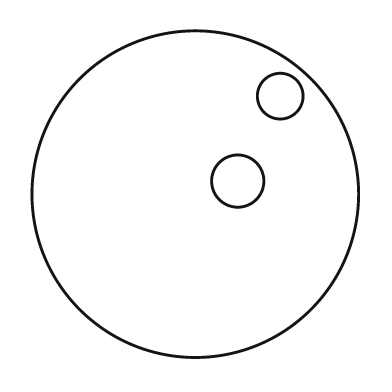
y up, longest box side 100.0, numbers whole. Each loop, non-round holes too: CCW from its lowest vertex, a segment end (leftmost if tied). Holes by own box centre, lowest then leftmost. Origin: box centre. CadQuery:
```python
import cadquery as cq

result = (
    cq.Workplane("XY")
    .moveTo(0.0, 0.0)
    .circle(50.0)
    .moveTo(13.0, 4.0)
    .circle(8.0)
    .moveTo(26.0, 30.0)
    .circle(7.0)
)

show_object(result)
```